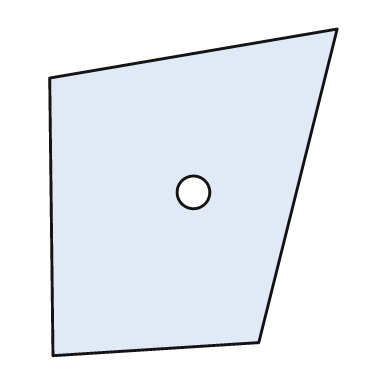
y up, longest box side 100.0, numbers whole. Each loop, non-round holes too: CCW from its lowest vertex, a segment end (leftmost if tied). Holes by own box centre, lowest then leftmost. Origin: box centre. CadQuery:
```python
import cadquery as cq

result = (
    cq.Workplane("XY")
    .moveTo(-43.0, -50.0)
    .lineTo(20.0, -46.0)
    .lineTo(44.0, 50.0)
    .lineTo(-44.0, 35.0)
    .close()
    .moveTo(0.0, 0.0)
    .circle(5.0)
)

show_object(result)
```